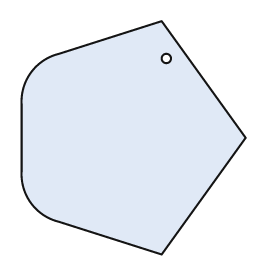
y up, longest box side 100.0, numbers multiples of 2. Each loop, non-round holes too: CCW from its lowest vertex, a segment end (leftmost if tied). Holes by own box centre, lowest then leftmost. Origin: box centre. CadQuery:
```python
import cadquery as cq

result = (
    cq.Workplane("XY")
    .moveTo(12.0, -50.0)
    .lineTo(48.0, 0.0)
    .lineTo(12.0, 50.0)
    .lineTo(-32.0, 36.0)
    .threePointArc((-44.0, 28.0), (-48.0, 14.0))
    .lineTo(-48.0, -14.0)
    .threePointArc((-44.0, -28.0), (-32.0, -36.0))
    .close()
    .moveTo(14.0, 34.0)
    .circle(2.0)
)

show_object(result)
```